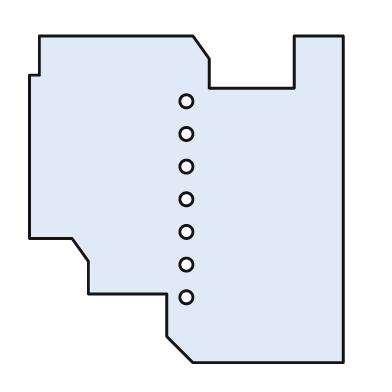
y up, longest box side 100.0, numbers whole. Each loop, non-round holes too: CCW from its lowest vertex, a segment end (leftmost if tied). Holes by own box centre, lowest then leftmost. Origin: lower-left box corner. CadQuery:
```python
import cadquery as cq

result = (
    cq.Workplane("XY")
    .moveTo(50.0, 0.0)
    .lineTo(96.0, 0.0)
    .lineTo(96.0, 100.0)
    .lineTo(81.0, 100.0)
    .lineTo(81.0, 84.0)
    .lineTo(55.0, 84.0)
    .lineTo(55.0, 93.0)
    .lineTo(50.0, 100.0)
    .lineTo(3.0, 100.0)
    .lineTo(3.0, 88.0)
    .lineTo(0.0, 88.0)
    .lineTo(0.0, 38.0)
    .lineTo(13.0, 38.0)
    .lineTo(18.0, 31.0)
    .lineTo(18.0, 21.0)
    .lineTo(42.0, 21.0)
    .lineTo(42.0, 8.0)
    .close()
    .moveTo(48.0, 20.0)
    .circle(2.0)
    .moveTo(48.0, 30.0)
    .circle(2.0)
    .moveTo(48.0, 40.0)
    .circle(2.0)
    .moveTo(48.0, 50.0)
    .circle(2.0)
    .moveTo(48.0, 60.0)
    .circle(2.0)
    .moveTo(48.0, 70.0)
    .circle(2.0)
    .moveTo(48.0, 80.0)
    .circle(2.0)
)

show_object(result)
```